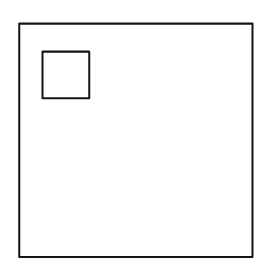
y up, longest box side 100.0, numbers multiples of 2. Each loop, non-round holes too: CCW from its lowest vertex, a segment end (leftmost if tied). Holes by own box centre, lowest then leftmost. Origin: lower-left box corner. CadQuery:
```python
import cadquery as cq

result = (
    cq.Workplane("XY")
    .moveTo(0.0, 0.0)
    .lineTo(100.0, 0.0)
    .lineTo(100.0, 100.0)
    .lineTo(0.0, 100.0)
    .close()
    .moveTo(10.0, 68.0)
    .lineTo(30.0, 68.0)
    .lineTo(30.0, 88.0)
    .lineTo(10.0, 88.0)
    .close()
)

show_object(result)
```